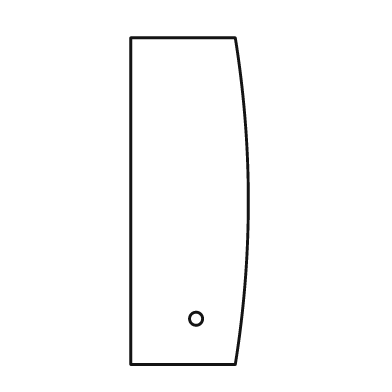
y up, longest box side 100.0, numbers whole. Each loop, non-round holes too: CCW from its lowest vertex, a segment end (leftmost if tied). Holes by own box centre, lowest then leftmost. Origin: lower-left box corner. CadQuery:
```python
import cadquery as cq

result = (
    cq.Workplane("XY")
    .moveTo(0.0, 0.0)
    .lineTo(32.0, 0.0)
    .threePointArc((36.0, 50.0), (32.0, 100.0))
    .lineTo(0.0, 100.0)
    .close()
    .moveTo(20.0, 14.0)
    .circle(2.0)
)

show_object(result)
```